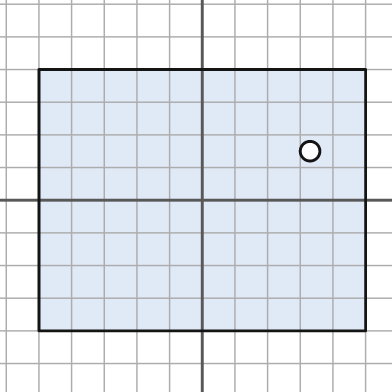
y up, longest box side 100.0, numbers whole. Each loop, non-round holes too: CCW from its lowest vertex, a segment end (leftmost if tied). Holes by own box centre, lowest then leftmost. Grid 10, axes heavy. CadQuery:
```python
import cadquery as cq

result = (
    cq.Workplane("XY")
    .moveTo(-50.0, -40.0)
    .lineTo(50.0, -40.0)
    .lineTo(50.0, 40.0)
    .lineTo(-50.0, 40.0)
    .close()
    .moveTo(33.0, 15.0)
    .circle(3.0)
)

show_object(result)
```